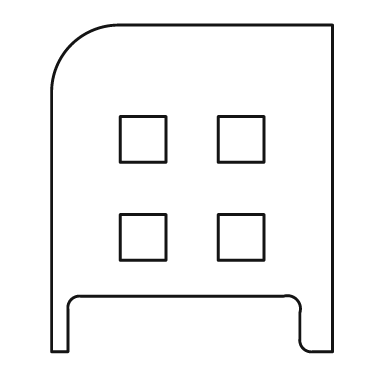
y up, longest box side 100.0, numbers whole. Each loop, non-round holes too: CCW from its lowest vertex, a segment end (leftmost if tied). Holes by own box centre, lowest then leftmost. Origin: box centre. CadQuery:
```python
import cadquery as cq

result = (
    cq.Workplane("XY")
    .moveTo(-43.0, -50.0)
    .lineTo(-38.0, -50.0)
    .lineTo(-38.0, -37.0)
    .threePointArc((-37.0, -34.0), (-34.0, -33.0))
    .lineTo(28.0, -33.0)
    .threePointArc((32.0, -34.0), (33.0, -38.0))
    .lineTo(33.0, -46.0)
    .threePointArc((34.0, -49.0), (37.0, -50.0))
    .lineTo(43.0, -50.0)
    .lineTo(43.0, 50.0)
    .lineTo(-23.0, 50.0)
    .threePointArc((-37.0, 44.0), (-43.0, 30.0))
    .close()
    .moveTo(-22.0, -22.0)
    .lineTo(-8.0, -22.0)
    .lineTo(-8.0, -8.0)
    .lineTo(-22.0, -8.0)
    .close()
    .moveTo(8.0, -22.0)
    .lineTo(22.0, -22.0)
    .lineTo(22.0, -8.0)
    .lineTo(8.0, -8.0)
    .close()
    .moveTo(-22.0, 8.0)
    .lineTo(-8.0, 8.0)
    .lineTo(-8.0, 22.0)
    .lineTo(-22.0, 22.0)
    .close()
    .moveTo(8.0, 8.0)
    .lineTo(22.0, 8.0)
    .lineTo(22.0, 22.0)
    .lineTo(8.0, 22.0)
    .close()
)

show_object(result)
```